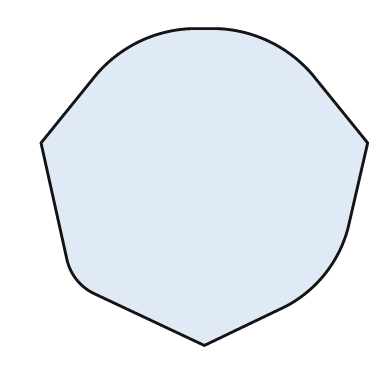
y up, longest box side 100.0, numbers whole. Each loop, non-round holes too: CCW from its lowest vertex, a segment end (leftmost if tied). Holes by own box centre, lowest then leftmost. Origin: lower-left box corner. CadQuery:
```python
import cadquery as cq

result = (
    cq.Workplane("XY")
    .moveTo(50.0, 0.0)
    .lineTo(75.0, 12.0)
    .threePointArc((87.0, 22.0), (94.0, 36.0))
    .lineTo(100.0, 62.0)
    .lineTo(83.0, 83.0)
    .threePointArc((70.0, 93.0), (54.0, 97.0))
    .lineTo(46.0, 97.0)
    .threePointArc((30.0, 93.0), (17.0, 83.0))
    .lineTo(0.0, 62.0)
    .lineTo(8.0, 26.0)
    .threePointArc((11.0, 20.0), (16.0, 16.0))
    .close()
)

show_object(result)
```